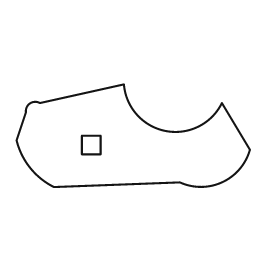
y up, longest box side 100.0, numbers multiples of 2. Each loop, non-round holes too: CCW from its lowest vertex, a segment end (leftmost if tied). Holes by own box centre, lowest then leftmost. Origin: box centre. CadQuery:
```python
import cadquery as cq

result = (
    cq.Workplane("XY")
    .moveTo(-34.0, -22.0)
    .lineTo(20.0, -20.0)
    .threePointArc((38.0, -20.0), (50.0, -6.0))
    .lineTo(38.0, 14.0)
    .threePointArc((14.0, 2.0), (-4.0, 22.0))
    .lineTo(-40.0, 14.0)
    .threePointArc((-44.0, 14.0), (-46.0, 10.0))
    .lineTo(-50.0, -2.0)
    .threePointArc((-44.0, -14.0), (-34.0, -22.0))
    .close()
    .moveTo(-22.0, -8.0)
    .lineTo(-14.0, -8.0)
    .lineTo(-14.0, 0.0)
    .lineTo(-22.0, 0.0)
    .close()
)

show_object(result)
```